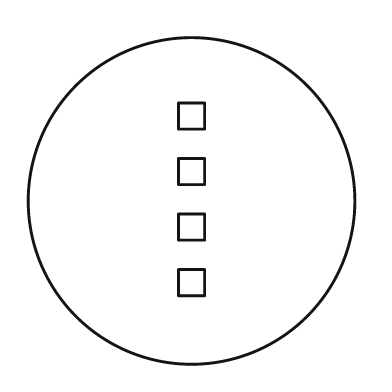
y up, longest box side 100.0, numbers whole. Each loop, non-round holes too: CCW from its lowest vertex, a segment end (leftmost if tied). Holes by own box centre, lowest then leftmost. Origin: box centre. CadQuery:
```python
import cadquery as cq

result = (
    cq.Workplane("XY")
    .moveTo(0.0, 0.0)
    .circle(50.0)
    .moveTo(-4.0, -29.0)
    .lineTo(4.0, -29.0)
    .lineTo(4.0, -21.0)
    .lineTo(-4.0, -21.0)
    .close()
    .moveTo(-4.0, -12.0)
    .lineTo(4.0, -12.0)
    .lineTo(4.0, -4.0)
    .lineTo(-4.0, -4.0)
    .close()
    .moveTo(-4.0, 5.0)
    .lineTo(4.0, 5.0)
    .lineTo(4.0, 13.0)
    .lineTo(-4.0, 13.0)
    .close()
    .moveTo(-4.0, 22.0)
    .lineTo(4.0, 22.0)
    .lineTo(4.0, 30.0)
    .lineTo(-4.0, 30.0)
    .close()
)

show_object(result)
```